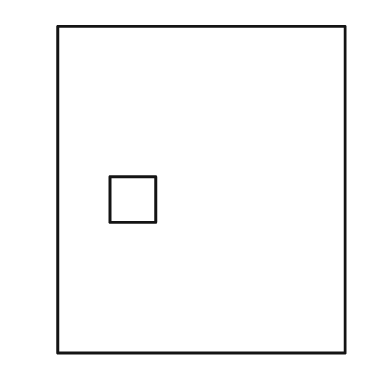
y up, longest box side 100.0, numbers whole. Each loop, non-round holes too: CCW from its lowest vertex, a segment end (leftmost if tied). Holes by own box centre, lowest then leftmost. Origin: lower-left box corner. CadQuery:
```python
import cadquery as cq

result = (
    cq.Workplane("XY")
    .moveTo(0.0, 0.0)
    .lineTo(88.0, 0.0)
    .lineTo(88.0, 100.0)
    .lineTo(0.0, 100.0)
    .close()
    .moveTo(16.0, 40.0)
    .lineTo(30.0, 40.0)
    .lineTo(30.0, 54.0)
    .lineTo(16.0, 54.0)
    .close()
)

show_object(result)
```